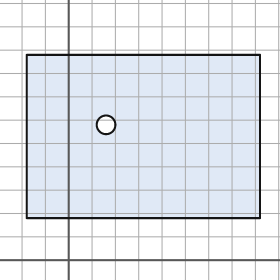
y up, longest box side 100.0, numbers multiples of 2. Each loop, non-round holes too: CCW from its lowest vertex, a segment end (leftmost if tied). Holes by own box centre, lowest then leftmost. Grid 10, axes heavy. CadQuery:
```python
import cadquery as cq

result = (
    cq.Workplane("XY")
    .moveTo(-18.0, 18.0)
    .lineTo(82.0, 18.0)
    .lineTo(82.0, 88.0)
    .lineTo(-18.0, 88.0)
    .close()
    .moveTo(16.0, 58.0)
    .circle(4.0)
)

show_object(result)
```